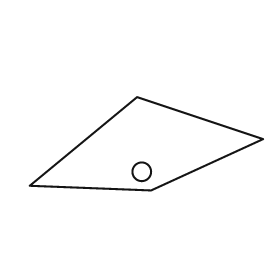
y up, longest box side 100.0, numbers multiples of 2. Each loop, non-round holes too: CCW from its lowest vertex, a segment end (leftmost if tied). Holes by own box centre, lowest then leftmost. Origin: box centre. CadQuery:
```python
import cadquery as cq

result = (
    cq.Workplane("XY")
    .moveTo(2.0, -20.0)
    .lineTo(50.0, 2.0)
    .lineTo(-4.0, 20.0)
    .lineTo(-50.0, -18.0)
    .close()
    .moveTo(-2.0, -12.0)
    .circle(4.0)
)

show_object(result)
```